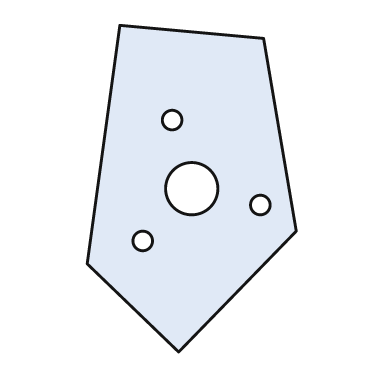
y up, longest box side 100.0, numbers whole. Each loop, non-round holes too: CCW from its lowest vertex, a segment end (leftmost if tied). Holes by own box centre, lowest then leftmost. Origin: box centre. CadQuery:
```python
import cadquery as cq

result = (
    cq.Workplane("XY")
    .moveTo(-4.0, -50.0)
    .lineTo(32.0, -13.0)
    .lineTo(22.0, 46.0)
    .lineTo(-22.0, 50.0)
    .lineTo(-32.0, -23.0)
    .close()
    .moveTo(-15.0, -16.0)
    .circle(3.0)
    .moveTo(21.0, -5.0)
    .circle(3.0)
    .moveTo(0.0, 0.0)
    .circle(8.0)
    .moveTo(-6.0, 21.0)
    .circle(3.0)
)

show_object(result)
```